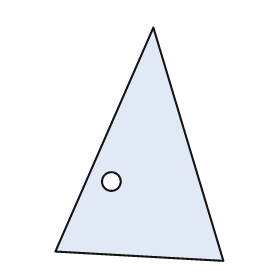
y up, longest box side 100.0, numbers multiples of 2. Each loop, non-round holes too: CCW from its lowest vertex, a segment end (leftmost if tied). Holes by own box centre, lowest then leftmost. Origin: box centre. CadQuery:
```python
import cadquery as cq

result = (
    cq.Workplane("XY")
    .moveTo(36.0, -50.0)
    .lineTo(6.0, 50.0)
    .lineTo(-36.0, -46.0)
    .close()
    .moveTo(-12.0, -16.0)
    .circle(4.0)
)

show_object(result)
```